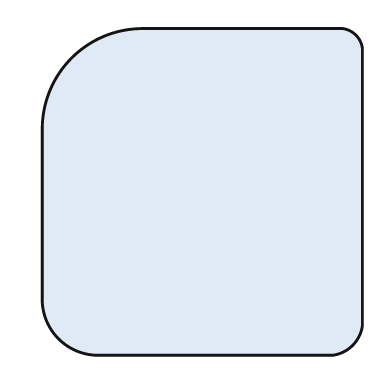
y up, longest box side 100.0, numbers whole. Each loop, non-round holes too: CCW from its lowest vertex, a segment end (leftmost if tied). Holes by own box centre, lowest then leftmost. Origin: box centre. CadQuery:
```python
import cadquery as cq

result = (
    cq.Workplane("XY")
    .moveTo(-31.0, -50.0)
    .lineTo(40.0, -50.0)
    .threePointArc((46.0, -47.0), (49.0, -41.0))
    .lineTo(49.0, 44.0)
    .threePointArc((47.0, 48.0), (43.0, 50.0))
    .lineTo(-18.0, 50.0)
    .threePointArc((-40.0, 41.0), (-49.0, 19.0))
    .lineTo(-49.0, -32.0)
    .threePointArc((-44.0, -45.0), (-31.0, -50.0))
    .close()
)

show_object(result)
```